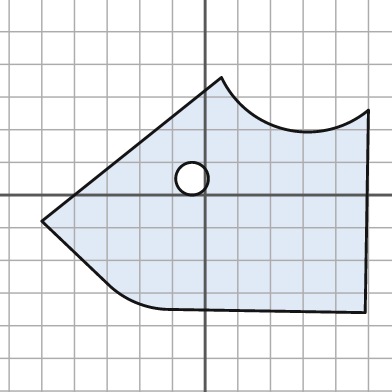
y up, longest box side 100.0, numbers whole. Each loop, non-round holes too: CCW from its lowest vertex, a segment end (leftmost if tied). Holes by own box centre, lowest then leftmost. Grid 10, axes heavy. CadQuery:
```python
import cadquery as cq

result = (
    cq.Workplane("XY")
    .moveTo(49.0, -36.0)
    .lineTo(50.0, 26.0)
    .threePointArc((25.0, 20.0), (5.0, 36.0))
    .lineTo(-50.0, -8.0)
    .lineTo(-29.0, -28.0)
    .threePointArc((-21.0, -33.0), (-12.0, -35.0))
    .close()
    .moveTo(-4.0, 5.0)
    .circle(5.0)
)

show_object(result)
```